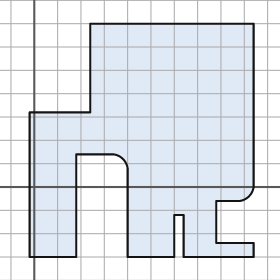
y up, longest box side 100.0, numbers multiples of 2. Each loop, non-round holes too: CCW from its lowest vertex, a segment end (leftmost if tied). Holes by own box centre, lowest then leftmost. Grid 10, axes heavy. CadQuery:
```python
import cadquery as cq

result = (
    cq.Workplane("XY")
    .moveTo(-2.0, -30.0)
    .lineTo(18.0, -30.0)
    .lineTo(18.0, 14.0)
    .lineTo(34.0, 14.0)
    .threePointArc((38.0, 12.0), (40.0, 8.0))
    .lineTo(40.0, -30.0)
    .lineTo(60.0, -30.0)
    .lineTo(60.0, -12.0)
    .lineTo(64.0, -12.0)
    .lineTo(64.0, -30.0)
    .lineTo(94.0, -30.0)
    .lineTo(94.0, -24.0)
    .lineTo(78.0, -24.0)
    .lineTo(78.0, -6.0)
    .lineTo(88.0, -6.0)
    .threePointArc((92.0, -4.0), (94.0, 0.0))
    .lineTo(94.0, 70.0)
    .lineTo(24.0, 70.0)
    .lineTo(24.0, 32.0)
    .lineTo(-2.0, 32.0)
    .close()
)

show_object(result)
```